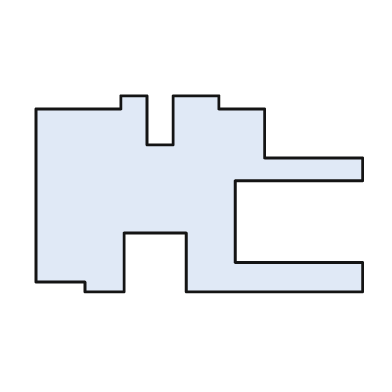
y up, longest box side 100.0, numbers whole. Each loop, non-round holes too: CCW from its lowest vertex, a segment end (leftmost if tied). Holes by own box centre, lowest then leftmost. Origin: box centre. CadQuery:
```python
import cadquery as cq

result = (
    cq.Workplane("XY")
    .moveTo(-35.0, -30.0)
    .lineTo(-23.0, -30.0)
    .lineTo(-23.0, -12.0)
    .lineTo(-4.0, -12.0)
    .lineTo(-4.0, -30.0)
    .lineTo(50.0, -30.0)
    .lineTo(50.0, -21.0)
    .lineTo(11.0, -21.0)
    .lineTo(11.0, 4.0)
    .lineTo(50.0, 4.0)
    .lineTo(50.0, 11.0)
    .lineTo(20.0, 11.0)
    .lineTo(20.0, 26.0)
    .lineTo(6.0, 26.0)
    .lineTo(6.0, 30.0)
    .lineTo(-8.0, 30.0)
    .lineTo(-8.0, 15.0)
    .lineTo(-16.0, 15.0)
    .lineTo(-16.0, 30.0)
    .lineTo(-24.0, 30.0)
    .lineTo(-24.0, 26.0)
    .lineTo(-50.0, 26.0)
    .lineTo(-50.0, -27.0)
    .lineTo(-35.0, -27.0)
    .close()
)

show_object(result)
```